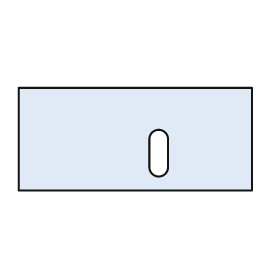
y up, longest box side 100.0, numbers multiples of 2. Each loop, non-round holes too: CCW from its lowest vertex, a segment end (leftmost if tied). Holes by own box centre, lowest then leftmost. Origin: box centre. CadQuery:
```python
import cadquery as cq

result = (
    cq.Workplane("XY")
    .moveTo(-50.0, -22.0)
    .lineTo(50.0, -22.0)
    .lineTo(50.0, 22.0)
    .lineTo(-50.0, 22.0)
    .close()
    .moveTo(6.0, -12.0)
    .threePointArc((10.0, -16.0), (14.0, -12.0))
    .lineTo(14.0, 0.0)
    .threePointArc((10.0, 4.0), (6.0, 0.0))
    .close()
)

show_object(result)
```